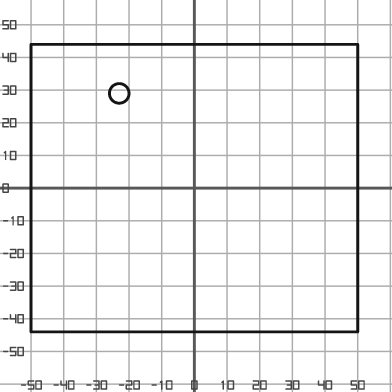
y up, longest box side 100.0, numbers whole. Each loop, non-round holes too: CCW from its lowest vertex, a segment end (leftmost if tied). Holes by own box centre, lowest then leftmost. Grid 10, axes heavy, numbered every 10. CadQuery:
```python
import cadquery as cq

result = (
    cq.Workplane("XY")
    .moveTo(-50.0, -44.0)
    .lineTo(50.0, -44.0)
    .lineTo(50.0, 44.0)
    .lineTo(-50.0, 44.0)
    .close()
    .moveTo(-23.0, 29.0)
    .circle(3.0)
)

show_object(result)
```